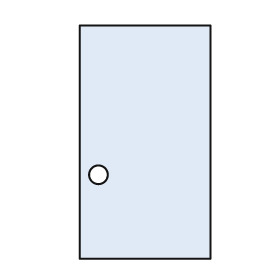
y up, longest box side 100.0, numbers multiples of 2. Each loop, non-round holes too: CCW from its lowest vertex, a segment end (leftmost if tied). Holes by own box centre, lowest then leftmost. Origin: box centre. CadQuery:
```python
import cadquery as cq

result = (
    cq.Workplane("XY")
    .moveTo(-28.0, -50.0)
    .lineTo(28.0, -50.0)
    .lineTo(28.0, 50.0)
    .lineTo(-28.0, 50.0)
    .close()
    .moveTo(-20.0, -14.0)
    .circle(4.0)
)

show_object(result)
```